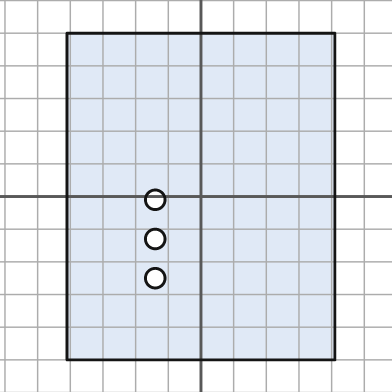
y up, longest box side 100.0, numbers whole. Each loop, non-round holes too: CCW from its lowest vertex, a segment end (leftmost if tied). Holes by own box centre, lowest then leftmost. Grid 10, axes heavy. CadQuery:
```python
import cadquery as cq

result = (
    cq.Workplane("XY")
    .moveTo(-41.0, -50.0)
    .lineTo(41.0, -50.0)
    .lineTo(41.0, 50.0)
    .lineTo(-41.0, 50.0)
    .close()
    .moveTo(-14.0, -25.0)
    .circle(3.0)
    .moveTo(-14.0, -13.0)
    .circle(3.0)
    .moveTo(-14.0, -1.0)
    .circle(3.0)
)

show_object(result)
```